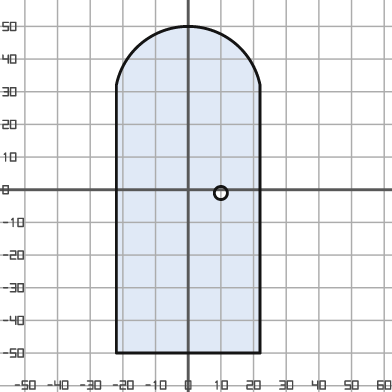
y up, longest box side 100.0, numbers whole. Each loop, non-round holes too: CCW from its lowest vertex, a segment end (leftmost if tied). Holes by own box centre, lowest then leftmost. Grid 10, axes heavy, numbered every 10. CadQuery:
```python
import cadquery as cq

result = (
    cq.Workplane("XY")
    .moveTo(-22.0, -50.0)
    .lineTo(22.0, -50.0)
    .lineTo(22.0, 32.0)
    .threePointArc((0.0, 50.0), (-22.0, 32.0))
    .close()
    .moveTo(10.0, -1.0)
    .circle(2.0)
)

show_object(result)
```